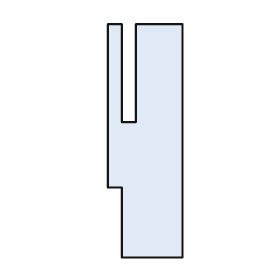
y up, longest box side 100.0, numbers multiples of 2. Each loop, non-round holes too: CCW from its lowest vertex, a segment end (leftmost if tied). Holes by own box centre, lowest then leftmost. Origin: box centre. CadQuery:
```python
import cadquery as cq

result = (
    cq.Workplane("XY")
    .moveTo(-10.0, -50.0)
    .lineTo(16.0, -50.0)
    .lineTo(16.0, 50.0)
    .lineTo(-4.0, 50.0)
    .lineTo(-4.0, 8.0)
    .lineTo(-10.0, 8.0)
    .lineTo(-10.0, 50.0)
    .lineTo(-16.0, 50.0)
    .lineTo(-16.0, -20.0)
    .lineTo(-10.0, -20.0)
    .close()
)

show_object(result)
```